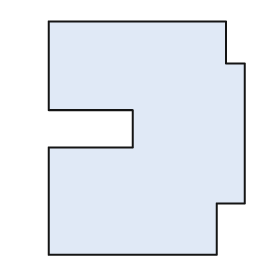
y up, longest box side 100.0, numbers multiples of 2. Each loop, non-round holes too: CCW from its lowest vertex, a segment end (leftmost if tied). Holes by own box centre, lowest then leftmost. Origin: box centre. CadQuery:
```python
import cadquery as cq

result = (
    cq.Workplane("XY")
    .moveTo(-42.0, -50.0)
    .lineTo(30.0, -50.0)
    .lineTo(30.0, -28.0)
    .lineTo(42.0, -28.0)
    .lineTo(42.0, 32.0)
    .lineTo(34.0, 32.0)
    .lineTo(34.0, 50.0)
    .lineTo(-42.0, 50.0)
    .lineTo(-42.0, 12.0)
    .lineTo(-6.0, 12.0)
    .lineTo(-6.0, -4.0)
    .lineTo(-42.0, -4.0)
    .close()
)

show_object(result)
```